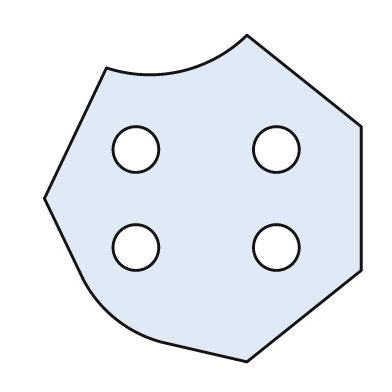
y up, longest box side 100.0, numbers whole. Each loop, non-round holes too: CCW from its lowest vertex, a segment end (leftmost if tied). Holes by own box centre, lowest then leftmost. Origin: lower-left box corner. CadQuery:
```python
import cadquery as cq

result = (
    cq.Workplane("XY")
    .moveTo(62.0, 0.0)
    .lineTo(97.0, 28.0)
    .lineTo(97.0, 72.0)
    .lineTo(62.0, 100.0)
    .threePointArc((42.0, 89.0), (19.0, 90.0))
    .lineTo(0.0, 50.0)
    .lineTo(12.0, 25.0)
    .threePointArc((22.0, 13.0), (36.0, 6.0))
    .close()
    .moveTo(28.0, 35.0)
    .circle(7.0)
    .moveTo(71.0, 35.0)
    .circle(7.0)
    .moveTo(28.0, 65.0)
    .circle(7.0)
    .moveTo(71.0, 65.0)
    .circle(7.0)
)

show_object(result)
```